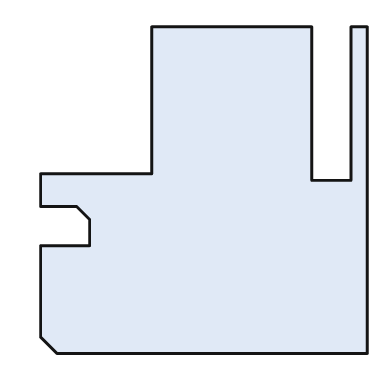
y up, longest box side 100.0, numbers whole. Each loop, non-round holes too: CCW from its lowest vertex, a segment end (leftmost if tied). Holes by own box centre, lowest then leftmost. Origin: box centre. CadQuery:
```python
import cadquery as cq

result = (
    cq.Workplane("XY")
    .moveTo(-45.0, -50.0)
    .lineTo(50.0, -50.0)
    .lineTo(50.0, 50.0)
    .lineTo(45.0, 50.0)
    .lineTo(45.0, 3.0)
    .lineTo(33.0, 3.0)
    .lineTo(33.0, 50.0)
    .lineTo(-16.0, 50.0)
    .lineTo(-16.0, 5.0)
    .lineTo(-50.0, 5.0)
    .lineTo(-50.0, -5.0)
    .lineTo(-39.0, -5.0)
    .lineTo(-35.0, -9.0)
    .lineTo(-35.0, -17.0)
    .lineTo(-50.0, -17.0)
    .lineTo(-50.0, -45.0)
    .close()
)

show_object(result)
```